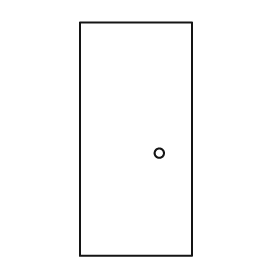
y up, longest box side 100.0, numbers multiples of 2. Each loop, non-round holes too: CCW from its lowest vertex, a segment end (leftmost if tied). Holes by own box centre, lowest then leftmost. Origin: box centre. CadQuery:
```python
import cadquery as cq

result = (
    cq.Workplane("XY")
    .moveTo(-24.0, -50.0)
    .lineTo(24.0, -50.0)
    .lineTo(24.0, 50.0)
    .lineTo(-24.0, 50.0)
    .close()
    .moveTo(10.0, -6.0)
    .circle(2.0)
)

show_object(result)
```